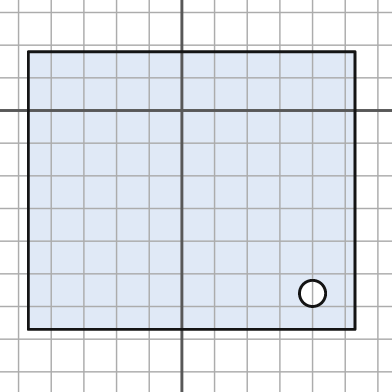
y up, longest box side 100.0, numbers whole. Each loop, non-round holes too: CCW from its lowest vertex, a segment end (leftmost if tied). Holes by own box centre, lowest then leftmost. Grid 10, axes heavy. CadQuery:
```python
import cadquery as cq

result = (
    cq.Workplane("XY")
    .moveTo(-47.0, -67.0)
    .lineTo(53.0, -67.0)
    .lineTo(53.0, 18.0)
    .lineTo(-47.0, 18.0)
    .close()
    .moveTo(40.0, -56.0)
    .circle(4.0)
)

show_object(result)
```